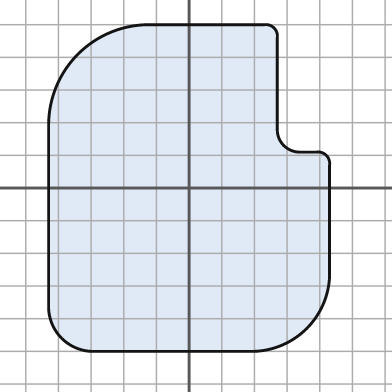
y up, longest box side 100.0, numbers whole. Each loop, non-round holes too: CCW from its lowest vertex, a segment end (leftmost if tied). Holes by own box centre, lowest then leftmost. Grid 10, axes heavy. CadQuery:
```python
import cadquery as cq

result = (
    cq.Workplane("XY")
    .moveTo(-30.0, -50.0)
    .lineTo(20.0, -50.0)
    .threePointArc((36.0, -43.0), (43.0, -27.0))
    .lineTo(43.0, 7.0)
    .threePointArc((42.0, 10.0), (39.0, 11.0))
    .lineTo(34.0, 11.0)
    .threePointArc((29.0, 13.0), (27.0, 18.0))
    .lineTo(27.0, 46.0)
    .threePointArc((26.0, 49.0), (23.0, 50.0))
    .lineTo(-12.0, 50.0)
    .threePointArc((-34.0, 41.0), (-43.0, 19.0))
    .lineTo(-43.0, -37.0)
    .threePointArc((-39.0, -46.0), (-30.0, -50.0))
    .close()
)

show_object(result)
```